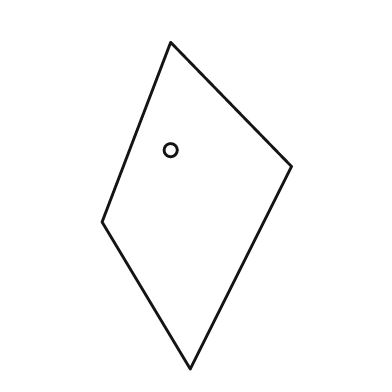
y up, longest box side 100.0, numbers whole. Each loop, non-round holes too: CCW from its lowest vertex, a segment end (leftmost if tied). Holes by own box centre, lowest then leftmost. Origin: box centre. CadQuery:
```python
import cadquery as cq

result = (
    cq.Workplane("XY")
    .moveTo(-2.0, -50.0)
    .lineTo(29.0, 12.0)
    .lineTo(-8.0, 50.0)
    .lineTo(-29.0, -5.0)
    .close()
    .moveTo(-8.0, 17.0)
    .circle(2.0)
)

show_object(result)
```